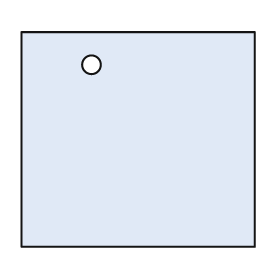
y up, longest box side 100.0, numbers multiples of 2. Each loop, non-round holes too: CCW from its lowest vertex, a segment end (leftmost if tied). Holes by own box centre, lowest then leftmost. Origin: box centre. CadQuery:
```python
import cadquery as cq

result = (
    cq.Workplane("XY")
    .moveTo(-50.0, -46.0)
    .lineTo(50.0, -46.0)
    .lineTo(50.0, 46.0)
    .lineTo(-50.0, 46.0)
    .close()
    .moveTo(-20.0, 32.0)
    .circle(4.0)
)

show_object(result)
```